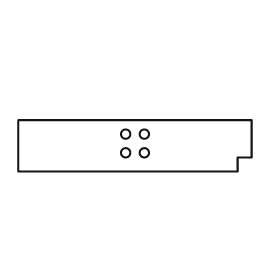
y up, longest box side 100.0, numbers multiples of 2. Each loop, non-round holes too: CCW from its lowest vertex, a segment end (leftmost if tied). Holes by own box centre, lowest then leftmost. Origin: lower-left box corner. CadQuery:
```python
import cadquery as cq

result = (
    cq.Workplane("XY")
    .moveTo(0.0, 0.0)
    .lineTo(94.0, 0.0)
    .lineTo(94.0, 6.0)
    .lineTo(100.0, 6.0)
    .lineTo(100.0, 22.0)
    .lineTo(0.0, 22.0)
    .close()
    .moveTo(46.0, 8.0)
    .circle(2.0)
    .moveTo(54.0, 8.0)
    .circle(2.0)
    .moveTo(46.0, 16.0)
    .circle(2.0)
    .moveTo(54.0, 16.0)
    .circle(2.0)
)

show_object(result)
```